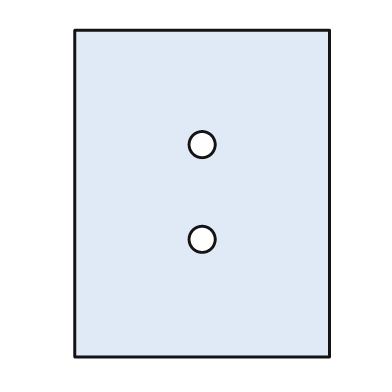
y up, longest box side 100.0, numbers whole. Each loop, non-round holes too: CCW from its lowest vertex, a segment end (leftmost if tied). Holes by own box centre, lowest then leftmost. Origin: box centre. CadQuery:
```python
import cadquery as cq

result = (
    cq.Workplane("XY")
    .moveTo(-39.0, -50.0)
    .lineTo(39.0, -50.0)
    .lineTo(39.0, 50.0)
    .lineTo(-39.0, 50.0)
    .close()
    .moveTo(0.0, -14.0)
    .circle(4.0)
    .moveTo(0.0, 15.0)
    .circle(4.0)
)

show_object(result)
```